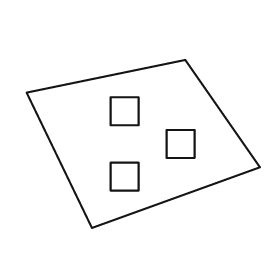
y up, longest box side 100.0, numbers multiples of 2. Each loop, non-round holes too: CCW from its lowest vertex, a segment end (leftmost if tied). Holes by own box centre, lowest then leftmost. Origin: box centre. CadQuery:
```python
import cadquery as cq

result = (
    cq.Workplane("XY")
    .moveTo(-22.0, -36.0)
    .lineTo(50.0, -10.0)
    .lineTo(18.0, 36.0)
    .lineTo(-50.0, 22.0)
    .close()
    .moveTo(-14.0, -20.0)
    .lineTo(-2.0, -20.0)
    .lineTo(-2.0, -8.0)
    .lineTo(-14.0, -8.0)
    .close()
    .moveTo(10.0, -6.0)
    .lineTo(22.0, -6.0)
    .lineTo(22.0, 6.0)
    .lineTo(10.0, 6.0)
    .close()
    .moveTo(-14.0, 8.0)
    .lineTo(-2.0, 8.0)
    .lineTo(-2.0, 20.0)
    .lineTo(-14.0, 20.0)
    .close()
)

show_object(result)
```